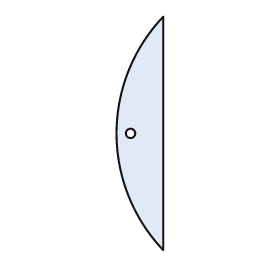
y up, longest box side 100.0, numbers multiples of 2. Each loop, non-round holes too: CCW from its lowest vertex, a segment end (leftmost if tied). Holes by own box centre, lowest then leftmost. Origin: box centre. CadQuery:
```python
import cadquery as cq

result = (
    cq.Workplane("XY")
    .moveTo(10.0, -50.0)
    .lineTo(10.0, 50.0)
    .threePointArc((-10.0, 0.0), (10.0, -50.0))
    .close()
    .moveTo(-4.0, 0.0)
    .circle(2.0)
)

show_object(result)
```